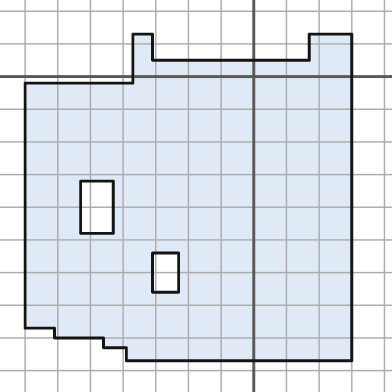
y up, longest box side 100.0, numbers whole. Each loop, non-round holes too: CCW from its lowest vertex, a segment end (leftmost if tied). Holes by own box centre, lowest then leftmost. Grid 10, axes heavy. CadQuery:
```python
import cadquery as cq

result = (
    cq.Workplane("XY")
    .moveTo(-39.0, -87.0)
    .lineTo(30.0, -87.0)
    .lineTo(30.0, 13.0)
    .lineTo(17.0, 13.0)
    .lineTo(17.0, 5.0)
    .lineTo(-31.0, 5.0)
    .lineTo(-31.0, 13.0)
    .lineTo(-37.0, 13.0)
    .lineTo(-37.0, -2.0)
    .lineTo(-70.0, -2.0)
    .lineTo(-70.0, -77.0)
    .lineTo(-61.0, -77.0)
    .lineTo(-61.0, -80.0)
    .lineTo(-46.0, -80.0)
    .lineTo(-46.0, -83.0)
    .lineTo(-39.0, -83.0)
    .close()
    .moveTo(-31.0, -66.0)
    .lineTo(-23.0, -66.0)
    .lineTo(-23.0, -54.0)
    .lineTo(-31.0, -54.0)
    .close()
    .moveTo(-53.0, -48.0)
    .lineTo(-43.0, -48.0)
    .lineTo(-43.0, -32.0)
    .lineTo(-53.0, -32.0)
    .close()
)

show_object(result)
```